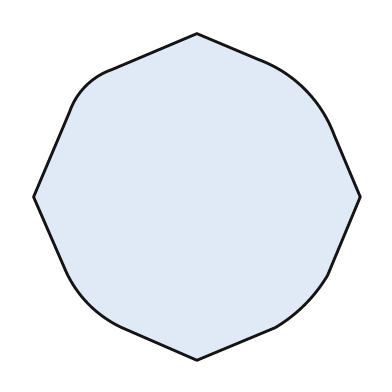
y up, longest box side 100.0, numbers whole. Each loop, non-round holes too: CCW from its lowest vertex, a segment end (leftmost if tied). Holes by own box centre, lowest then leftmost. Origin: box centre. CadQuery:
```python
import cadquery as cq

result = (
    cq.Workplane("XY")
    .moveTo(0.0, -50.0)
    .lineTo(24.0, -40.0)
    .threePointArc((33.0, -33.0), (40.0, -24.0))
    .lineTo(50.0, 0.0)
    .lineTo(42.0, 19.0)
    .threePointArc((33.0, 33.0), (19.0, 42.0))
    .lineTo(0.0, 50.0)
    .lineTo(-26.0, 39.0)
    .threePointArc((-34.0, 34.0), (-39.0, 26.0))
    .lineTo(-50.0, 0.0)
    .lineTo(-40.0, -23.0)
    .threePointArc((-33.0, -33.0), (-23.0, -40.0))
    .close()
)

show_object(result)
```